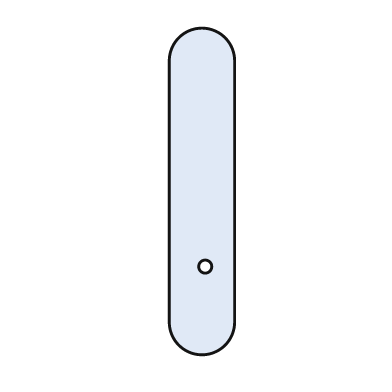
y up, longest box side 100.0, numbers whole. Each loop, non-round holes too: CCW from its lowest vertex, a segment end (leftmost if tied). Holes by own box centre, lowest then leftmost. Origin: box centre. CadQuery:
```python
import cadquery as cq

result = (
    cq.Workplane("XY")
    .moveTo(-10.0, -40.0)
    .threePointArc((0.0, -50.0), (10.0, -40.0))
    .lineTo(10.0, 40.0)
    .threePointArc((0.0, 50.0), (-10.0, 40.0))
    .close()
    .moveTo(1.0, -23.0)
    .circle(2.0)
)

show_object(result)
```